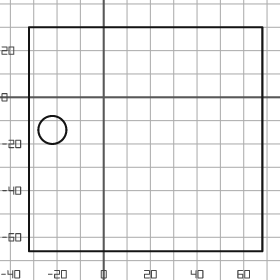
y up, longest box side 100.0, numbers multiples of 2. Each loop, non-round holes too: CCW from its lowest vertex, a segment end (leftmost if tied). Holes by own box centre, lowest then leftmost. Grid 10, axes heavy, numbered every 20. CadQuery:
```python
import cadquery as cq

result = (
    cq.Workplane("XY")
    .moveTo(-32.0, -66.0)
    .lineTo(68.0, -66.0)
    .lineTo(68.0, 30.0)
    .lineTo(-32.0, 30.0)
    .close()
    .moveTo(-22.0, -14.0)
    .circle(6.0)
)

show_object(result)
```